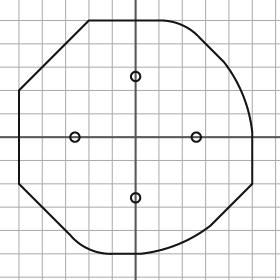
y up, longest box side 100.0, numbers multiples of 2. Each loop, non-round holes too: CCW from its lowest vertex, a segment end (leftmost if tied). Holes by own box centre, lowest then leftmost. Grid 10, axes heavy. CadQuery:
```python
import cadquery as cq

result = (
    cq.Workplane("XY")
    .moveTo(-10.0, -50.0)
    .lineTo(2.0, -50.0)
    .threePointArc((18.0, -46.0), (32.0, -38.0))
    .lineTo(50.0, -20.0)
    .lineTo(50.0, 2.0)
    .threePointArc((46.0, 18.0), (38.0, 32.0))
    .lineTo(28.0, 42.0)
    .threePointArc((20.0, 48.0), (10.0, 50.0))
    .lineTo(-20.0, 50.0)
    .lineTo(-50.0, 20.0)
    .lineTo(-50.0, -20.0)
    .lineTo(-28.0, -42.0)
    .threePointArc((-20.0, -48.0), (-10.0, -50.0))
    .close()
    .moveTo(0.0, -26.0)
    .circle(2.0)
    .moveTo(-26.0, 0.0)
    .circle(2.0)
    .moveTo(26.0, 0.0)
    .circle(2.0)
    .moveTo(0.0, 26.0)
    .circle(2.0)
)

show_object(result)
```